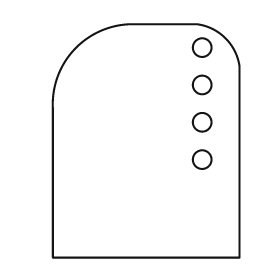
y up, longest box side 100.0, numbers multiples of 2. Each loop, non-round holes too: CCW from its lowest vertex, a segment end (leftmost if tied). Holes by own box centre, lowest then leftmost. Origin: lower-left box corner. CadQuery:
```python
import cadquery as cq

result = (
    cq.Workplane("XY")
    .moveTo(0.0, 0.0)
    .lineTo(80.0, 0.0)
    .lineTo(80.0, 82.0)
    .threePointArc((74.0, 94.0), (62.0, 100.0))
    .lineTo(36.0, 100.0)
    .threePointArc((10.0, 90.0), (0.0, 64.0))
    .close()
    .moveTo(64.0, 42.0)
    .circle(4.0)
    .moveTo(64.0, 58.0)
    .circle(4.0)
    .moveTo(64.0, 74.0)
    .circle(4.0)
    .moveTo(64.0, 90.0)
    .circle(4.0)
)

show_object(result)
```